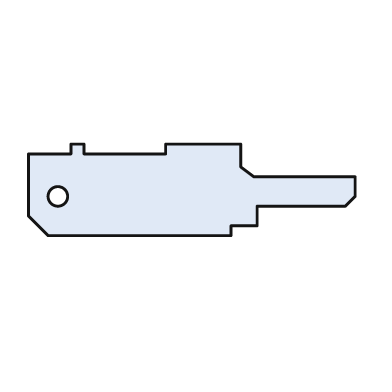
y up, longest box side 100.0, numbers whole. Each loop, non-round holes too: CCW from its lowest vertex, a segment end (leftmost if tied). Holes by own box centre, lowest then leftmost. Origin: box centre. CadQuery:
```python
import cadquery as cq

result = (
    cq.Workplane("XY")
    .moveTo(-44.0, -14.0)
    .lineTo(12.0, -14.0)
    .lineTo(12.0, -11.0)
    .lineTo(20.0, -11.0)
    .lineTo(20.0, -5.0)
    .lineTo(47.0, -5.0)
    .lineTo(50.0, -2.0)
    .lineTo(50.0, 4.0)
    .lineTo(19.0, 4.0)
    .lineTo(15.0, 7.0)
    .lineTo(15.0, 14.0)
    .lineTo(-8.0, 14.0)
    .lineTo(-8.0, 11.0)
    .lineTo(-33.0, 11.0)
    .lineTo(-33.0, 14.0)
    .lineTo(-37.0, 14.0)
    .lineTo(-37.0, 11.0)
    .lineTo(-50.0, 11.0)
    .lineTo(-50.0, -8.0)
    .close()
    .moveTo(-41.0, -2.0)
    .circle(3.0)
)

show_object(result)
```